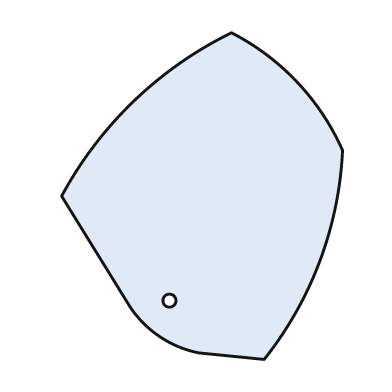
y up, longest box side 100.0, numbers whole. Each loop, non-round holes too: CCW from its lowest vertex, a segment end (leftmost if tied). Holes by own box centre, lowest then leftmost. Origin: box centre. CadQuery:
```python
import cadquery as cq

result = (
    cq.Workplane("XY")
    .moveTo(19.0, -50.0)
    .threePointArc((36.0, -20.0), (43.0, 14.0))
    .threePointArc((29.0, 35.0), (9.0, 50.0))
    .threePointArc((-21.0, 29.0), (-43.0, 0.0))
    .lineTo(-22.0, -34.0)
    .threePointArc((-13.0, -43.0), (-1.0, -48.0))
    .close()
    .moveTo(-10.0, -32.0)
    .circle(2.0)
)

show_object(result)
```